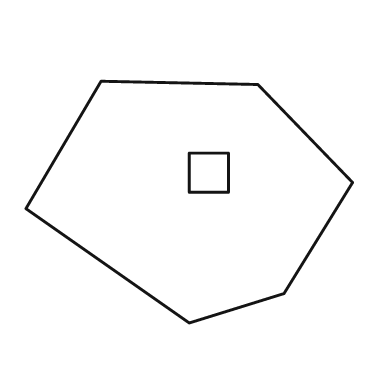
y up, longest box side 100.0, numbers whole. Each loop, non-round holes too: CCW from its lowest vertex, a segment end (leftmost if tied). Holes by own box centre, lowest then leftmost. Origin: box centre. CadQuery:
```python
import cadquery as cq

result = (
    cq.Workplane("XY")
    .moveTo(0.0, -37.0)
    .lineTo(29.0, -28.0)
    .lineTo(50.0, 6.0)
    .lineTo(21.0, 36.0)
    .lineTo(-27.0, 37.0)
    .lineTo(-50.0, -2.0)
    .close()
    .moveTo(0.0, 3.0)
    .lineTo(12.0, 3.0)
    .lineTo(12.0, 15.0)
    .lineTo(0.0, 15.0)
    .close()
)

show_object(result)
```